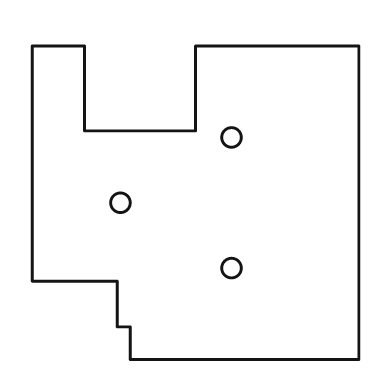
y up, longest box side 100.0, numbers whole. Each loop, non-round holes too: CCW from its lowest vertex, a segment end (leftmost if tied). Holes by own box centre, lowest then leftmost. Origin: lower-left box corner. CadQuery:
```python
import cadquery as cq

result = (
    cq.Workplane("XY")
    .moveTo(30.0, 0.0)
    .lineTo(100.0, 0.0)
    .lineTo(100.0, 96.0)
    .lineTo(50.0, 96.0)
    .lineTo(50.0, 70.0)
    .lineTo(16.0, 70.0)
    .lineTo(16.0, 96.0)
    .lineTo(0.0, 96.0)
    .lineTo(0.0, 24.0)
    .lineTo(26.0, 24.0)
    .lineTo(26.0, 10.0)
    .lineTo(30.0, 10.0)
    .close()
    .moveTo(61.0, 28.0)
    .circle(3.0)
    .moveTo(27.0, 48.0)
    .circle(3.0)
    .moveTo(61.0, 68.0)
    .circle(3.0)
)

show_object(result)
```